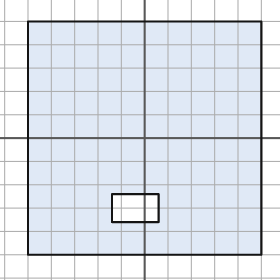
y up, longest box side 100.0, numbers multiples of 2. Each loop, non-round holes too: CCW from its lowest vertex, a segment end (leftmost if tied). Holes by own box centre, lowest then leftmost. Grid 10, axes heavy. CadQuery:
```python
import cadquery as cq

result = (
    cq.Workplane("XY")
    .moveTo(-50.0, -50.0)
    .lineTo(50.0, -50.0)
    .lineTo(50.0, 50.0)
    .lineTo(-50.0, 50.0)
    .close()
    .moveTo(-14.0, -36.0)
    .lineTo(6.0, -36.0)
    .lineTo(6.0, -24.0)
    .lineTo(-14.0, -24.0)
    .close()
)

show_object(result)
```